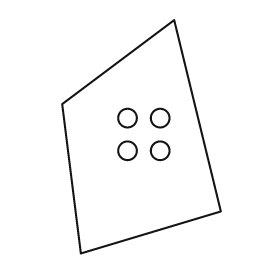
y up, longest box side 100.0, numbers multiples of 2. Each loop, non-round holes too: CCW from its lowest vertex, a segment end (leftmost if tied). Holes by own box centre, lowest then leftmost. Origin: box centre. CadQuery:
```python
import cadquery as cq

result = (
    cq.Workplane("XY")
    .moveTo(-26.0, -50.0)
    .lineTo(34.0, -32.0)
    .lineTo(14.0, 50.0)
    .lineTo(-34.0, 14.0)
    .close()
    .moveTo(-6.0, -6.0)
    .circle(4.0)
    .moveTo(8.0, -6.0)
    .circle(4.0)
    .moveTo(-6.0, 8.0)
    .circle(4.0)
    .moveTo(8.0, 8.0)
    .circle(4.0)
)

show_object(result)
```